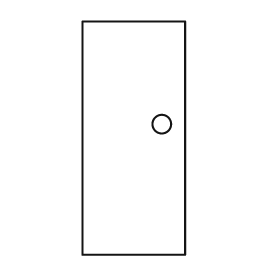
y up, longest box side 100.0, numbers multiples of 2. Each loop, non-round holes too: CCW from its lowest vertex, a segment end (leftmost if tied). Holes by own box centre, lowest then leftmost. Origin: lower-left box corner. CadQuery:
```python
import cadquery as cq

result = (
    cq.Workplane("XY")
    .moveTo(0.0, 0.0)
    .lineTo(44.0, 0.0)
    .lineTo(44.0, 100.0)
    .lineTo(0.0, 100.0)
    .close()
    .moveTo(34.0, 56.0)
    .circle(4.0)
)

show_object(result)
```